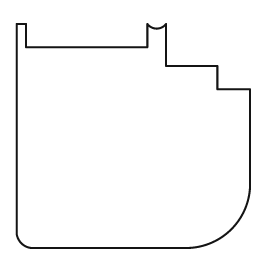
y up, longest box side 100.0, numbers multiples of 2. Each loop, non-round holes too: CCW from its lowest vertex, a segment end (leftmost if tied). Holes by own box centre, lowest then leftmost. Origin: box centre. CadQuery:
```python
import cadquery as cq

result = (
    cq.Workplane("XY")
    .moveTo(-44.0, -48.0)
    .lineTo(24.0, -48.0)
    .threePointArc((42.0, -40.0), (50.0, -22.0))
    .lineTo(50.0, 20.0)
    .lineTo(36.0, 20.0)
    .lineTo(36.0, 30.0)
    .lineTo(14.0, 30.0)
    .lineTo(14.0, 48.0)
    .threePointArc((10.0, 46.0), (6.0, 48.0))
    .lineTo(6.0, 38.0)
    .lineTo(-46.0, 38.0)
    .lineTo(-46.0, 48.0)
    .lineTo(-50.0, 48.0)
    .lineTo(-50.0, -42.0)
    .threePointArc((-48.0, -46.0), (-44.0, -48.0))
    .close()
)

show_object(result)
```